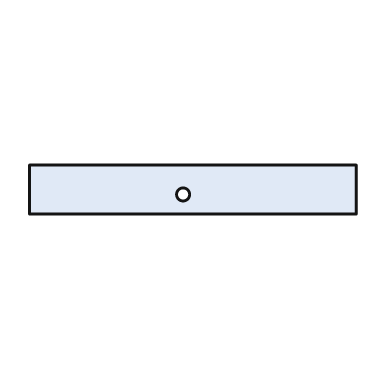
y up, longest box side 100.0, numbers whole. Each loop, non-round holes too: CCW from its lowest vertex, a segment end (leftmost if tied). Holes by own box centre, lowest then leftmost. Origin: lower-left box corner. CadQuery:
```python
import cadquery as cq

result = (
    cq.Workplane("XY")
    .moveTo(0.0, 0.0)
    .lineTo(100.0, 0.0)
    .lineTo(100.0, 15.0)
    .lineTo(0.0, 15.0)
    .close()
    .moveTo(47.0, 6.0)
    .circle(2.0)
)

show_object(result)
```